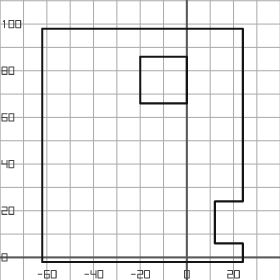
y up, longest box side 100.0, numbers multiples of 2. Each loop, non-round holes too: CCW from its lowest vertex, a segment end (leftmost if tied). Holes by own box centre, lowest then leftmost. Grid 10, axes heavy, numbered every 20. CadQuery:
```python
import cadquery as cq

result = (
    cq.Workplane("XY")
    .moveTo(-62.0, -2.0)
    .lineTo(24.0, -2.0)
    .lineTo(24.0, 6.0)
    .lineTo(12.0, 6.0)
    .lineTo(12.0, 24.0)
    .lineTo(24.0, 24.0)
    .lineTo(24.0, 98.0)
    .lineTo(-62.0, 98.0)
    .close()
    .moveTo(-20.0, 66.0)
    .lineTo(0.0, 66.0)
    .lineTo(0.0, 86.0)
    .lineTo(-20.0, 86.0)
    .close()
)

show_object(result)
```